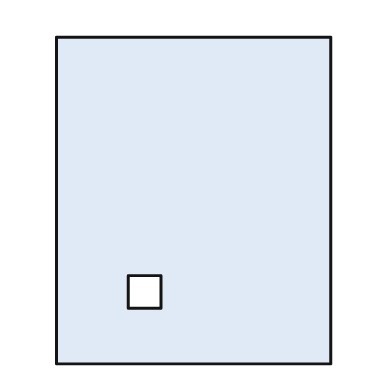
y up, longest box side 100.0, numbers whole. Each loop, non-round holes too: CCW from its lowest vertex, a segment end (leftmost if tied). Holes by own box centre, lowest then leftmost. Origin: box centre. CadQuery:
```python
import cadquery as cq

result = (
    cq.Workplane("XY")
    .moveTo(-42.0, -50.0)
    .lineTo(42.0, -50.0)
    .lineTo(42.0, 50.0)
    .lineTo(-42.0, 50.0)
    .close()
    .moveTo(-20.0, -33.0)
    .lineTo(-10.0, -33.0)
    .lineTo(-10.0, -23.0)
    .lineTo(-20.0, -23.0)
    .close()
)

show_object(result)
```